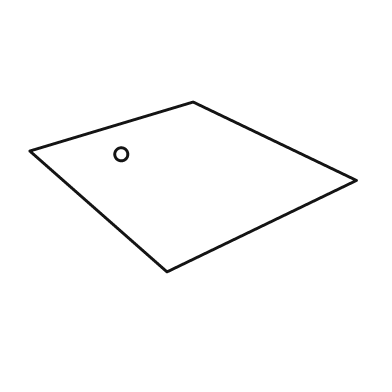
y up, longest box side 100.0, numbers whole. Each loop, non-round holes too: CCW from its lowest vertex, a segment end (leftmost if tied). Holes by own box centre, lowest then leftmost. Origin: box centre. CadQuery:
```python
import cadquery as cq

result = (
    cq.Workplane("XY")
    .moveTo(-8.0, -26.0)
    .lineTo(50.0, 2.0)
    .lineTo(0.0, 26.0)
    .lineTo(-50.0, 11.0)
    .close()
    .moveTo(-22.0, 10.0)
    .circle(2.0)
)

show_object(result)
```